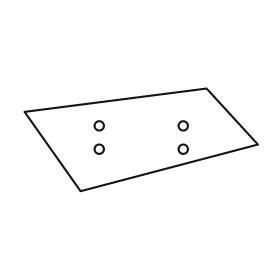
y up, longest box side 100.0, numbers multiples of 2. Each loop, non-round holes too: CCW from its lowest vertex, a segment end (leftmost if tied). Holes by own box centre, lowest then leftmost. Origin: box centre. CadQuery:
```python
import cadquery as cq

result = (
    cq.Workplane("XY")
    .moveTo(-26.0, -22.0)
    .lineTo(50.0, -2.0)
    .lineTo(28.0, 22.0)
    .lineTo(-50.0, 12.0)
    .close()
    .moveTo(-18.0, -4.0)
    .circle(2.0)
    .moveTo(18.0, -4.0)
    .circle(2.0)
    .moveTo(-18.0, 6.0)
    .circle(2.0)
    .moveTo(18.0, 6.0)
    .circle(2.0)
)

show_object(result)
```